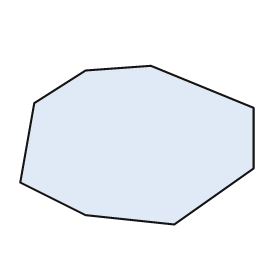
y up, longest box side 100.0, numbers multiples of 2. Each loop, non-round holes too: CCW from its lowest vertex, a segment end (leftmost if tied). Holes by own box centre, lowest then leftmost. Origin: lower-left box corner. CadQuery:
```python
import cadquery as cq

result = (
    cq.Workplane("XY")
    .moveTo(66.0, 0.0)
    .lineTo(100.0, 24.0)
    .lineTo(100.0, 50.0)
    .lineTo(56.0, 68.0)
    .lineTo(28.0, 66.0)
    .lineTo(6.0, 52.0)
    .lineTo(0.0, 18.0)
    .lineTo(28.0, 4.0)
    .close()
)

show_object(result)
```